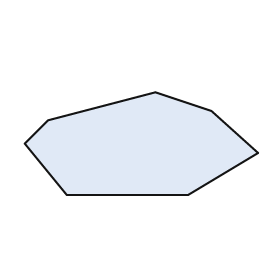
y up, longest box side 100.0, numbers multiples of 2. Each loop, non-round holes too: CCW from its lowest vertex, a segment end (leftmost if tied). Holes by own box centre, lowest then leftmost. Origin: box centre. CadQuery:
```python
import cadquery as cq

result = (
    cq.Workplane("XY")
    .moveTo(-32.0, -22.0)
    .lineTo(20.0, -22.0)
    .lineTo(50.0, -4.0)
    .lineTo(30.0, 14.0)
    .lineTo(6.0, 22.0)
    .lineTo(-40.0, 10.0)
    .lineTo(-50.0, 0.0)
    .close()
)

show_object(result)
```